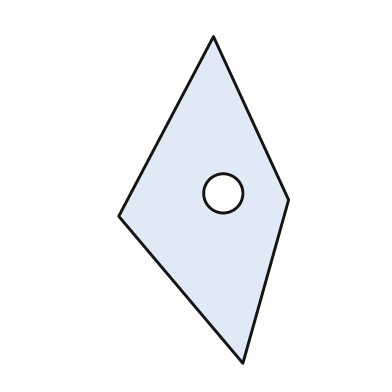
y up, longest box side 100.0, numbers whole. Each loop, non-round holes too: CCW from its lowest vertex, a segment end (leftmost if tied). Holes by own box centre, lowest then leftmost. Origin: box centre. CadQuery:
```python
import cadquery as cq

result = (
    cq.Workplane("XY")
    .moveTo(12.0, -50.0)
    .lineTo(26.0, 0.0)
    .lineTo(3.0, 50.0)
    .lineTo(-26.0, -5.0)
    .close()
    .moveTo(6.0, 2.0)
    .circle(6.0)
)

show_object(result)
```